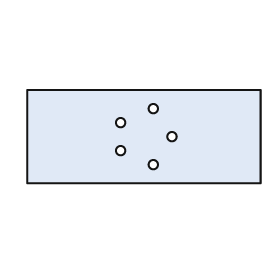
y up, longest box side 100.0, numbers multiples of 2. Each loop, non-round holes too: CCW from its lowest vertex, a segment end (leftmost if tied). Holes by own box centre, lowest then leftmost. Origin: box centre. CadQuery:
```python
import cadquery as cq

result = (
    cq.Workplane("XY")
    .moveTo(-50.0, -20.0)
    .lineTo(50.0, -20.0)
    .lineTo(50.0, 20.0)
    .lineTo(-50.0, 20.0)
    .close()
    .moveTo(4.0, -12.0)
    .circle(2.0)
    .moveTo(-10.0, -6.0)
    .circle(2.0)
    .moveTo(12.0, 0.0)
    .circle(2.0)
    .moveTo(-10.0, 6.0)
    .circle(2.0)
    .moveTo(4.0, 12.0)
    .circle(2.0)
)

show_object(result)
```